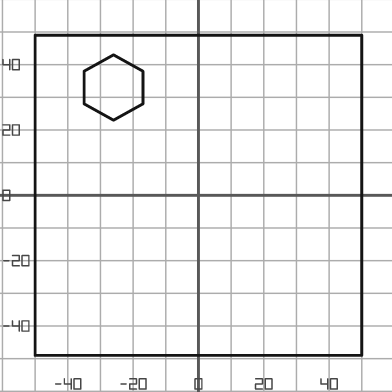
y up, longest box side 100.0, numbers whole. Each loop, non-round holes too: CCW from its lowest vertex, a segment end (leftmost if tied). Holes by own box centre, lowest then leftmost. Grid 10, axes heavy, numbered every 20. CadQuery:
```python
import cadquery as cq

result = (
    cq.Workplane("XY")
    .moveTo(-50.0, -49.0)
    .lineTo(50.0, -49.0)
    .lineTo(50.0, 49.0)
    .lineTo(-50.0, 49.0)
    .close()
    .moveTo(-26.0, 23.0)
    .lineTo(-17.0, 28.0)
    .lineTo(-17.0, 38.0)
    .lineTo(-26.0, 43.0)
    .lineTo(-35.0, 38.0)
    .lineTo(-35.0, 28.0)
    .close()
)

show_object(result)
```